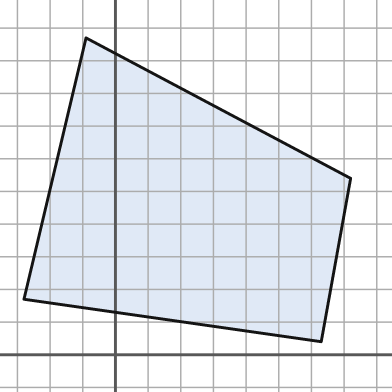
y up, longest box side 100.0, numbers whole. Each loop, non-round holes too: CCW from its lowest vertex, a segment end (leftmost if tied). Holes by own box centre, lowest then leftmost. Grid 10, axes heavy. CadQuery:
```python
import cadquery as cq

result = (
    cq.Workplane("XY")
    .moveTo(63.0, 4.0)
    .lineTo(72.0, 54.0)
    .lineTo(-9.0, 97.0)
    .lineTo(-28.0, 17.0)
    .close()
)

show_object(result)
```